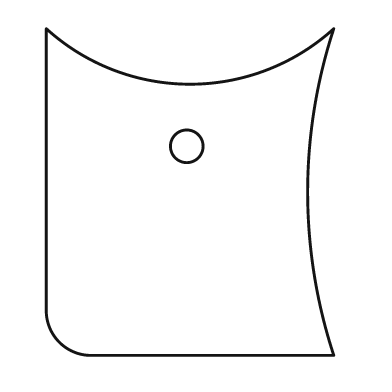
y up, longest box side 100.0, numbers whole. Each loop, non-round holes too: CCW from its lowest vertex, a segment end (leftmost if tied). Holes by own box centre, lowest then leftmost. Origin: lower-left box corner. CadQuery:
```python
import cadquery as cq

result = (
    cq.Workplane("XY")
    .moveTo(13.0, 0.0)
    .lineTo(88.0, 0.0)
    .threePointArc((80.0, 50.0), (88.0, 100.0))
    .threePointArc((44.0, 83.0), (0.0, 100.0))
    .lineTo(0.0, 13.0)
    .threePointArc((4.0, 4.0), (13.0, 0.0))
    .close()
    .moveTo(43.0, 64.0)
    .circle(5.0)
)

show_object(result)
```